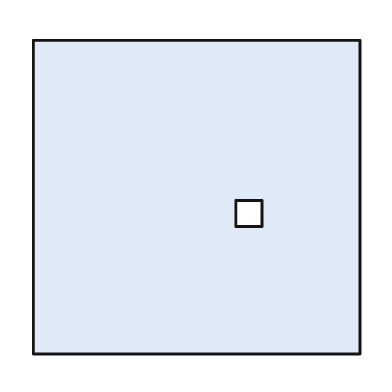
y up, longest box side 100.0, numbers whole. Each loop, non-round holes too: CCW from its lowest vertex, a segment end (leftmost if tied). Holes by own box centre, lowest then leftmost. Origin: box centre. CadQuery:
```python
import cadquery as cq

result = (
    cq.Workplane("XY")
    .moveTo(-50.0, -48.0)
    .lineTo(50.0, -48.0)
    .lineTo(50.0, 48.0)
    .lineTo(-50.0, 48.0)
    .close()
    .moveTo(12.0, -9.0)
    .lineTo(20.0, -9.0)
    .lineTo(20.0, -1.0)
    .lineTo(12.0, -1.0)
    .close()
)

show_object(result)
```